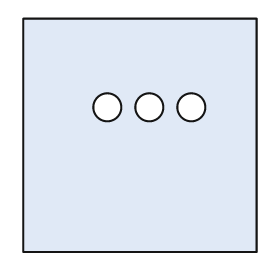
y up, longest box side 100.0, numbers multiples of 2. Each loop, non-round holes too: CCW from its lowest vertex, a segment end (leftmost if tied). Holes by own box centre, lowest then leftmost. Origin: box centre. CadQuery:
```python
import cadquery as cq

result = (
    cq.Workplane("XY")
    .moveTo(-50.0, -50.0)
    .lineTo(50.0, -50.0)
    .lineTo(50.0, 50.0)
    .lineTo(-50.0, 50.0)
    .close()
    .moveTo(-14.0, 12.0)
    .circle(6.0)
    .moveTo(4.0, 12.0)
    .circle(6.0)
    .moveTo(22.0, 12.0)
    .circle(6.0)
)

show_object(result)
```